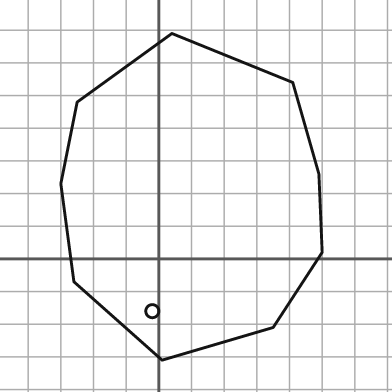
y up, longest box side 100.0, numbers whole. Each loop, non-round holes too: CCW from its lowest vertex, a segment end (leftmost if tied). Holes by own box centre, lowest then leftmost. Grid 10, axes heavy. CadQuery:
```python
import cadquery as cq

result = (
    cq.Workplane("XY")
    .moveTo(1.0, -31.0)
    .lineTo(35.0, -21.0)
    .lineTo(50.0, 2.0)
    .lineTo(49.0, 26.0)
    .lineTo(41.0, 54.0)
    .lineTo(4.0, 69.0)
    .lineTo(-25.0, 48.0)
    .lineTo(-30.0, 23.0)
    .lineTo(-26.0, -7.0)
    .close()
    .moveTo(-2.0, -16.0)
    .circle(2.0)
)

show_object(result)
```